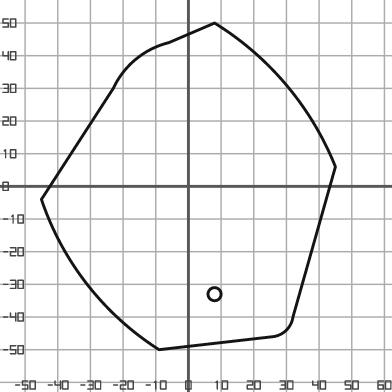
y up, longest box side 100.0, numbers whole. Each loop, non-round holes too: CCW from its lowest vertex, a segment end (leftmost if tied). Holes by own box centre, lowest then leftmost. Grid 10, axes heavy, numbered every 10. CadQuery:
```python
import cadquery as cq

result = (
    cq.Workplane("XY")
    .moveTo(-9.0, -50.0)
    .lineTo(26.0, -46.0)
    .threePointArc((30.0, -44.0), (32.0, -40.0))
    .lineTo(45.0, 6.0)
    .threePointArc((30.0, 31.0), (8.0, 50.0))
    .lineTo(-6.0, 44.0)
    .threePointArc((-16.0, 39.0), (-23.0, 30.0))
    .lineTo(-45.0, -4.0)
    .threePointArc((-31.0, -30.0), (-9.0, -50.0))
    .close()
    .moveTo(8.0, -33.0)
    .circle(2.0)
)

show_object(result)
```